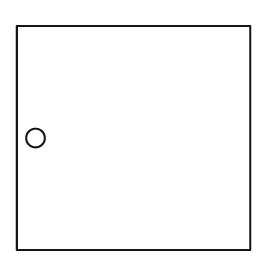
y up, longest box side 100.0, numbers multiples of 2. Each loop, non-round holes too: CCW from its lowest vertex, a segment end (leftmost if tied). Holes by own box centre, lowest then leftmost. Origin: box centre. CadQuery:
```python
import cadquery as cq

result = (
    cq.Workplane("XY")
    .moveTo(-50.0, -48.0)
    .lineTo(50.0, -48.0)
    .lineTo(50.0, 48.0)
    .lineTo(-50.0, 48.0)
    .close()
    .moveTo(-42.0, 0.0)
    .circle(4.0)
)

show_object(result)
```